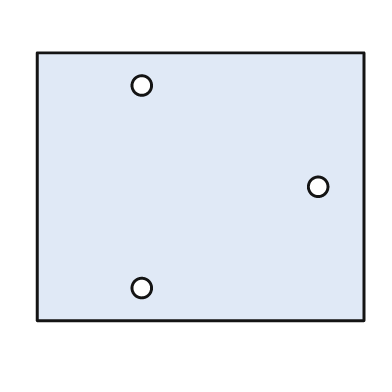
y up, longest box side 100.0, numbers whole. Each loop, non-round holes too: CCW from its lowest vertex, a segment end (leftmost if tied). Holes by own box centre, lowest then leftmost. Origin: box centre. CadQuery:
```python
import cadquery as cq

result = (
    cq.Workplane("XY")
    .moveTo(-50.0, -41.0)
    .lineTo(50.0, -41.0)
    .lineTo(50.0, 41.0)
    .lineTo(-50.0, 41.0)
    .close()
    .moveTo(-18.0, -31.0)
    .circle(3.0)
    .moveTo(36.0, 0.0)
    .circle(3.0)
    .moveTo(-18.0, 31.0)
    .circle(3.0)
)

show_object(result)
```